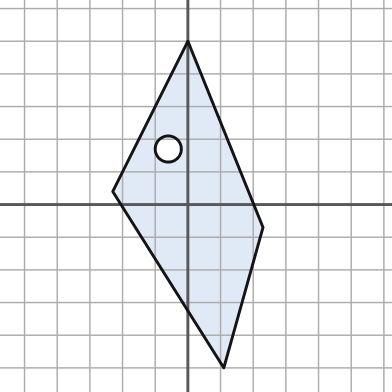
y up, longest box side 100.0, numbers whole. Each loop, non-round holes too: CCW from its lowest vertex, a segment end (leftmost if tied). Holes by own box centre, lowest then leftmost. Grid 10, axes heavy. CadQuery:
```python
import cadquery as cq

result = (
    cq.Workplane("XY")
    .moveTo(11.0, -50.0)
    .lineTo(23.0, -7.0)
    .lineTo(0.0, 50.0)
    .lineTo(-23.0, 4.0)
    .close()
    .moveTo(-6.0, 17.0)
    .circle(4.0)
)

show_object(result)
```